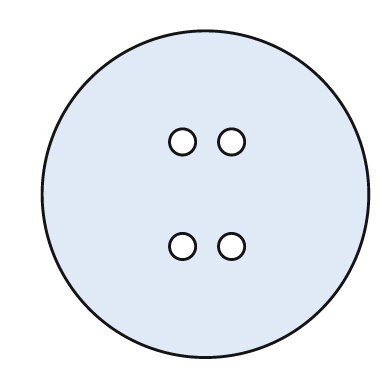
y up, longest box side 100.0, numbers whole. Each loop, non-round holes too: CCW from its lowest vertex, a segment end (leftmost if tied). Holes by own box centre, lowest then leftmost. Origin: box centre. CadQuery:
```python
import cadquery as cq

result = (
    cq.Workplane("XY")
    .moveTo(0.0, 0.0)
    .circle(50.0)
    .moveTo(-7.0, -16.0)
    .circle(4.0)
    .moveTo(8.0, -16.0)
    .circle(4.0)
    .moveTo(-7.0, 16.0)
    .circle(4.0)
    .moveTo(8.0, 16.0)
    .circle(4.0)
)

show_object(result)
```